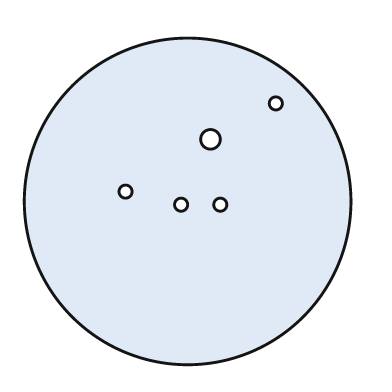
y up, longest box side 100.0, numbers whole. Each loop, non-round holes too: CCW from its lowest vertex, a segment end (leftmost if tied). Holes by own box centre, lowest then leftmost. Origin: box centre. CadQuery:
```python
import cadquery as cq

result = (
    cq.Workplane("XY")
    .moveTo(0.0, 0.0)
    .circle(50.0)
    .moveTo(-2.0, -1.0)
    .circle(2.0)
    .moveTo(10.0, -1.0)
    .circle(2.0)
    .moveTo(-19.0, 3.0)
    .circle(2.0)
    .moveTo(7.0, 19.0)
    .circle(3.0)
    .moveTo(27.0, 30.0)
    .circle(2.0)
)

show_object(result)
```